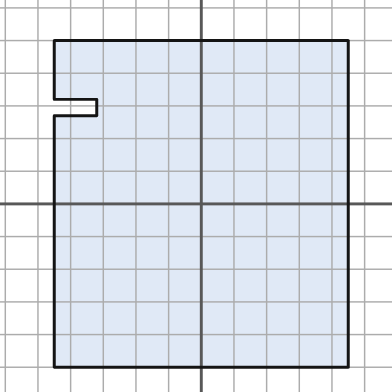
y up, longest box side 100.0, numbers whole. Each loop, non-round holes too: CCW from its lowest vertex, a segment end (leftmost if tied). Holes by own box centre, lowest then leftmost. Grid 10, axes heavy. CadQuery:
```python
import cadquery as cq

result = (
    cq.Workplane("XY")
    .moveTo(-45.0, -50.0)
    .lineTo(45.0, -50.0)
    .lineTo(45.0, 50.0)
    .lineTo(-45.0, 50.0)
    .lineTo(-45.0, 32.0)
    .lineTo(-32.0, 32.0)
    .lineTo(-32.0, 27.0)
    .lineTo(-45.0, 27.0)
    .close()
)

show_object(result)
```